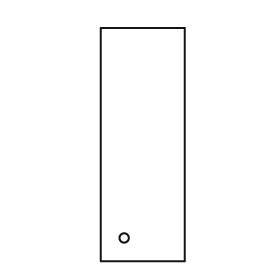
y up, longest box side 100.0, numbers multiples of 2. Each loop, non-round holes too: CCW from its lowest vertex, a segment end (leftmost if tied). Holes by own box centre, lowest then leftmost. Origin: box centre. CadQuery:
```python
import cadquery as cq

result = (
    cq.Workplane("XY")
    .moveTo(-18.0, -50.0)
    .lineTo(18.0, -50.0)
    .lineTo(18.0, 50.0)
    .lineTo(-18.0, 50.0)
    .close()
    .moveTo(-8.0, -40.0)
    .circle(2.0)
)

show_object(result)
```